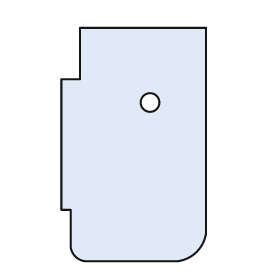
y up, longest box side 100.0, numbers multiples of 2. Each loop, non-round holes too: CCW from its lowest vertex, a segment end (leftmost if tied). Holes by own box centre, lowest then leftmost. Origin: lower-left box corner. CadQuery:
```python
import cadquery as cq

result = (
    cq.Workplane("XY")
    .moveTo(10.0, 0.0)
    .lineTo(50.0, 0.0)
    .threePointArc((58.0, 4.0), (62.0, 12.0))
    .lineTo(62.0, 100.0)
    .lineTo(8.0, 100.0)
    .lineTo(8.0, 78.0)
    .lineTo(0.0, 78.0)
    .lineTo(0.0, 22.0)
    .lineTo(4.0, 22.0)
    .lineTo(4.0, 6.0)
    .threePointArc((6.0, 2.0), (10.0, 0.0))
    .close()
    .moveTo(38.0, 68.0)
    .circle(4.0)
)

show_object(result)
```